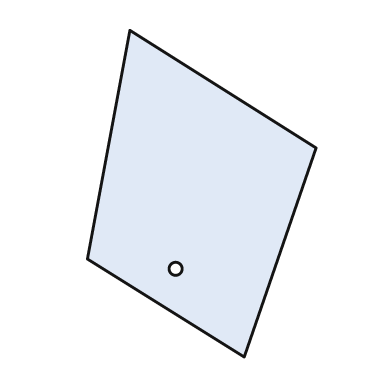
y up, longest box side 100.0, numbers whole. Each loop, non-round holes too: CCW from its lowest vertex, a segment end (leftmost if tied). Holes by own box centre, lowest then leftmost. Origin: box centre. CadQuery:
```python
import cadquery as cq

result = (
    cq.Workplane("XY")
    .moveTo(13.0, -50.0)
    .lineTo(35.0, 14.0)
    .lineTo(-22.0, 50.0)
    .lineTo(-35.0, -20.0)
    .close()
    .moveTo(-8.0, -23.0)
    .circle(2.0)
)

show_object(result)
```